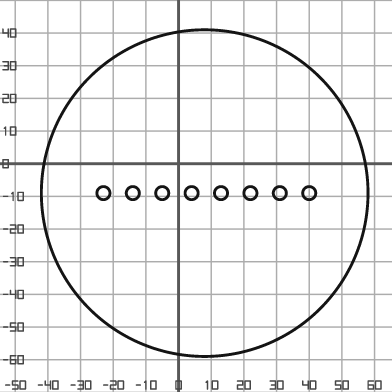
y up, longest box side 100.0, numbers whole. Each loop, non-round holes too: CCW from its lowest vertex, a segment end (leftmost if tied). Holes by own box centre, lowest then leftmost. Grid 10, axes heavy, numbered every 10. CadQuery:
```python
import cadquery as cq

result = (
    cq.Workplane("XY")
    .moveTo(8.0, -9.0)
    .circle(50.0)
    .moveTo(-23.0, -9.0)
    .circle(2.0)
    .moveTo(-14.0, -9.0)
    .circle(2.0)
    .moveTo(-5.0, -9.0)
    .circle(2.0)
    .moveTo(4.0, -9.0)
    .circle(2.0)
    .moveTo(13.0, -9.0)
    .circle(2.0)
    .moveTo(22.0, -9.0)
    .circle(2.0)
    .moveTo(31.0, -9.0)
    .circle(2.0)
    .moveTo(40.0, -9.0)
    .circle(2.0)
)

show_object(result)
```